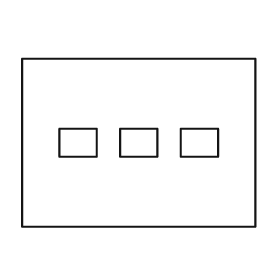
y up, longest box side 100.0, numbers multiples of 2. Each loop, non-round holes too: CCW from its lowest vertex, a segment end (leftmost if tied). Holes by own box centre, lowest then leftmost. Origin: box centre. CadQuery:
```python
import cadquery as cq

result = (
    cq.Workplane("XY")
    .moveTo(-50.0, -36.0)
    .lineTo(50.0, -36.0)
    .lineTo(50.0, 36.0)
    .lineTo(-50.0, 36.0)
    .close()
    .moveTo(-34.0, -6.0)
    .lineTo(-18.0, -6.0)
    .lineTo(-18.0, 6.0)
    .lineTo(-34.0, 6.0)
    .close()
    .moveTo(-8.0, -6.0)
    .lineTo(8.0, -6.0)
    .lineTo(8.0, 6.0)
    .lineTo(-8.0, 6.0)
    .close()
    .moveTo(18.0, -6.0)
    .lineTo(34.0, -6.0)
    .lineTo(34.0, 6.0)
    .lineTo(18.0, 6.0)
    .close()
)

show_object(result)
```